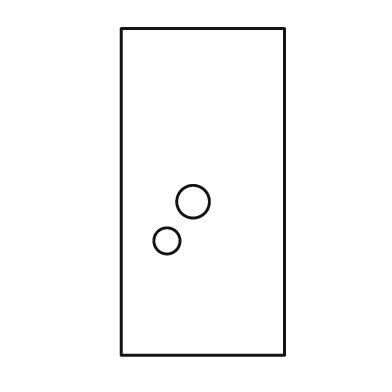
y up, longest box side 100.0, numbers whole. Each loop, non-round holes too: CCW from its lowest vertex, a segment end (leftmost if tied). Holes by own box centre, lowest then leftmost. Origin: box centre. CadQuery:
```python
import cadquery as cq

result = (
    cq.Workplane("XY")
    .moveTo(-25.0, -50.0)
    .lineTo(25.0, -50.0)
    .lineTo(25.0, 50.0)
    .lineTo(-25.0, 50.0)
    .close()
    .moveTo(-11.0, -15.0)
    .circle(4.0)
    .moveTo(-3.0, -3.0)
    .circle(5.0)
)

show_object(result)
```